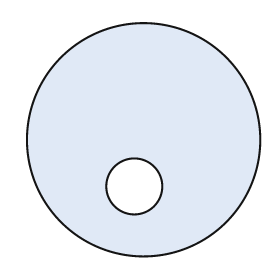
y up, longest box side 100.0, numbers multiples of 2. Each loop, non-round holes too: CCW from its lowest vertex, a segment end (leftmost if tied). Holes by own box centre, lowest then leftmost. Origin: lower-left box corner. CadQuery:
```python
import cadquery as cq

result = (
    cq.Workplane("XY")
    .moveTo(50.0, 50.0)
    .circle(50.0)
    .moveTo(46.0, 30.0)
    .circle(12.0)
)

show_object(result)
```